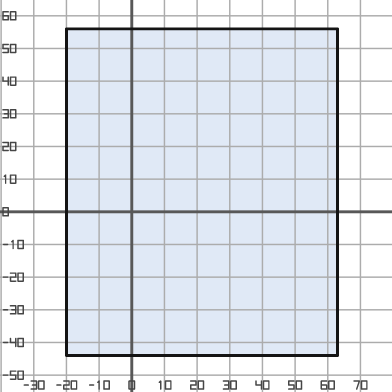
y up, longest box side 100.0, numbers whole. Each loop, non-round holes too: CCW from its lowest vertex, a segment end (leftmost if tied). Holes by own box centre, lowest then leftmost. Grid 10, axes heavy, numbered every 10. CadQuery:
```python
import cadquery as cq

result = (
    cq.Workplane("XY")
    .moveTo(-20.0, -44.0)
    .lineTo(63.0, -44.0)
    .lineTo(63.0, 56.0)
    .lineTo(-20.0, 56.0)
    .close()
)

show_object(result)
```